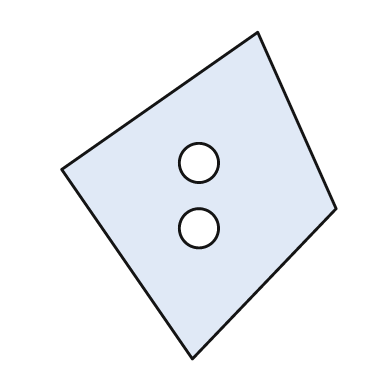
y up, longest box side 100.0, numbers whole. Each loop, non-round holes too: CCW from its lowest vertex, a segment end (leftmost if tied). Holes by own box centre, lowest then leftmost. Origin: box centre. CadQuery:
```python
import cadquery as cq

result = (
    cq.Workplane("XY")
    .moveTo(-2.0, -50.0)
    .lineTo(42.0, -4.0)
    .lineTo(18.0, 50.0)
    .lineTo(-42.0, 8.0)
    .close()
    .moveTo(0.0, -10.0)
    .circle(6.0)
    .moveTo(0.0, 10.0)
    .circle(6.0)
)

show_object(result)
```